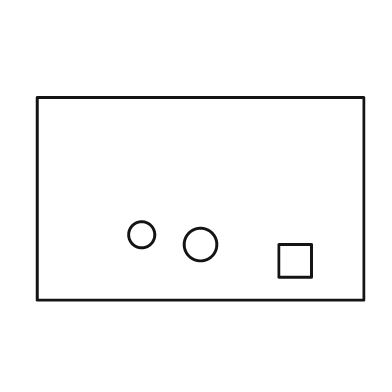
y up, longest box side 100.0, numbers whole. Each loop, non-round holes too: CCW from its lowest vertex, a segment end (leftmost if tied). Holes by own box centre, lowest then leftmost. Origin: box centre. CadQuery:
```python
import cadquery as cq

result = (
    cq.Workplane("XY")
    .moveTo(-50.0, -31.0)
    .lineTo(50.0, -31.0)
    .lineTo(50.0, 31.0)
    .lineTo(-50.0, 31.0)
    .close()
    .moveTo(24.0, -24.0)
    .lineTo(34.0, -24.0)
    .lineTo(34.0, -14.0)
    .lineTo(24.0, -14.0)
    .close()
    .moveTo(0.0, -14.0)
    .circle(5.0)
    .moveTo(-18.0, -11.0)
    .circle(4.0)
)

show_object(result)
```